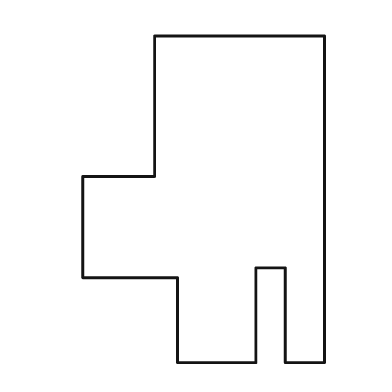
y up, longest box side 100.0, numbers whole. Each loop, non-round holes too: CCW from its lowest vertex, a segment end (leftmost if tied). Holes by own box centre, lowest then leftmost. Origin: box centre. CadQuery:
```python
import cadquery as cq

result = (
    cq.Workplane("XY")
    .moveTo(-8.0, -50.0)
    .lineTo(16.0, -50.0)
    .lineTo(16.0, -21.0)
    .lineTo(25.0, -21.0)
    .lineTo(25.0, -50.0)
    .lineTo(37.0, -50.0)
    .lineTo(37.0, 50.0)
    .lineTo(-15.0, 50.0)
    .lineTo(-15.0, 7.0)
    .lineTo(-37.0, 7.0)
    .lineTo(-37.0, -24.0)
    .lineTo(-8.0, -24.0)
    .close()
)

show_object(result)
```